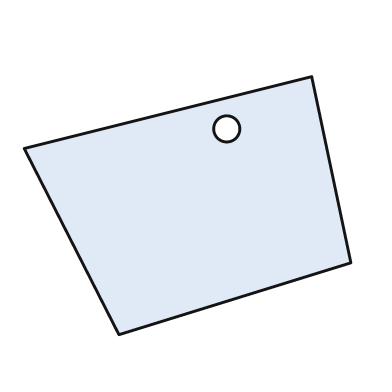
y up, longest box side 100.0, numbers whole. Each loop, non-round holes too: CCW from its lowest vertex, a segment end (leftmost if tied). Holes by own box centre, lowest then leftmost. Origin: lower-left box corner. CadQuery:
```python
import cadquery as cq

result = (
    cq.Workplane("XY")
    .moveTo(29.0, 0.0)
    .lineTo(100.0, 22.0)
    .lineTo(88.0, 79.0)
    .lineTo(0.0, 57.0)
    .close()
    .moveTo(62.0, 63.0)
    .circle(4.0)
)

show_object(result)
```